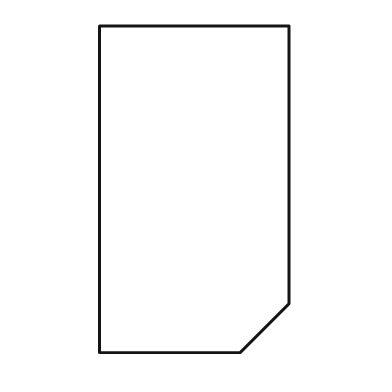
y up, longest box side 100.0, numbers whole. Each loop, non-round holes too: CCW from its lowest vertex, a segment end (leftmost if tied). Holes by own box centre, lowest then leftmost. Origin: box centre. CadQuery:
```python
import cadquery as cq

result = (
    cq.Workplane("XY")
    .moveTo(-29.0, -50.0)
    .lineTo(14.0, -50.0)
    .lineTo(29.0, -35.0)
    .lineTo(29.0, 50.0)
    .lineTo(-29.0, 50.0)
    .close()
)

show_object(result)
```